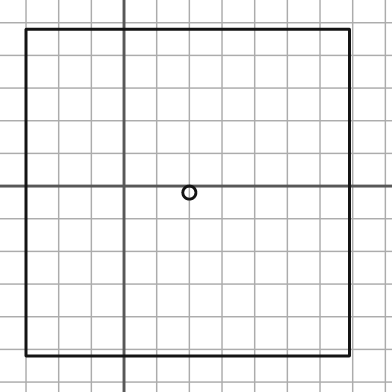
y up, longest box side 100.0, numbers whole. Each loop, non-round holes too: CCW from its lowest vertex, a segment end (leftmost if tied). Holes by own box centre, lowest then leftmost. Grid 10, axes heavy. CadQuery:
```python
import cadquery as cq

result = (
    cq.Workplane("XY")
    .moveTo(-30.0, -52.0)
    .lineTo(69.0, -52.0)
    .lineTo(69.0, 48.0)
    .lineTo(-30.0, 48.0)
    .close()
    .moveTo(20.0, -2.0)
    .circle(2.0)
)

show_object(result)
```